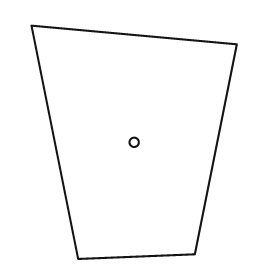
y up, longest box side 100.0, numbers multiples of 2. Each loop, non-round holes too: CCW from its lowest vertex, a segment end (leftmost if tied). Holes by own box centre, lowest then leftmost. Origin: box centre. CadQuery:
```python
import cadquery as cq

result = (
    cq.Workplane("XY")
    .moveTo(-24.0, -50.0)
    .lineTo(26.0, -48.0)
    .lineTo(44.0, 42.0)
    .lineTo(-44.0, 50.0)
    .close()
    .moveTo(0.0, 0.0)
    .circle(2.0)
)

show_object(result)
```